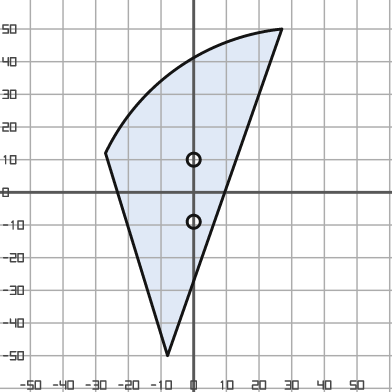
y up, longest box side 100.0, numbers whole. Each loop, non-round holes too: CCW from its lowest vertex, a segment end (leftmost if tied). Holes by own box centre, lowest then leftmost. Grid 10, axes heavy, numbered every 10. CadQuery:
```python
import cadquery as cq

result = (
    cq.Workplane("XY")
    .moveTo(-8.0, -50.0)
    .lineTo(27.0, 50.0)
    .threePointArc((-5.0, 38.0), (-27.0, 12.0))
    .close()
    .moveTo(0.0, -9.0)
    .circle(2.0)
    .moveTo(0.0, 10.0)
    .circle(2.0)
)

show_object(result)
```